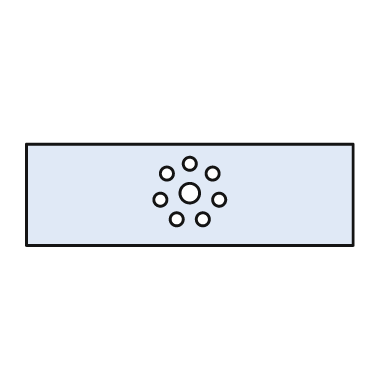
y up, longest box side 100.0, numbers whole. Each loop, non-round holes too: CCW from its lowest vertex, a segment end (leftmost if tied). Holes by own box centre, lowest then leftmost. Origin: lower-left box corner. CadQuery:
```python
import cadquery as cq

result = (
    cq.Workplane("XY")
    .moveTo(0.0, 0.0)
    .lineTo(100.0, 0.0)
    .lineTo(100.0, 31.0)
    .lineTo(0.0, 31.0)
    .close()
    .moveTo(46.0, 8.0)
    .circle(2.0)
    .moveTo(54.0, 8.0)
    .circle(2.0)
    .moveTo(41.0, 14.0)
    .circle(2.0)
    .moveTo(59.0, 14.0)
    .circle(2.0)
    .moveTo(50.0, 16.0)
    .circle(3.0)
    .moveTo(43.0, 22.0)
    .circle(2.0)
    .moveTo(57.0, 22.0)
    .circle(2.0)
    .moveTo(50.0, 25.0)
    .circle(2.0)
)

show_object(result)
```